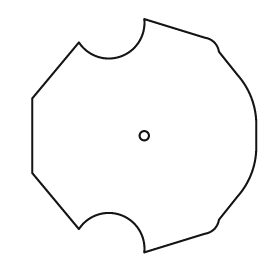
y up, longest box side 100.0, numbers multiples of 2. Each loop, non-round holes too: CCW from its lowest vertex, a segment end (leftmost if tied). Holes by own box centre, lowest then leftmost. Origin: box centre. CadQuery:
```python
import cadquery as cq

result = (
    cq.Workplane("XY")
    .moveTo(0.0, -50.0)
    .lineTo(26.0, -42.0)
    .threePointArc((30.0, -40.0), (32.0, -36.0))
    .lineTo(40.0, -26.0)
    .threePointArc((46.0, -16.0), (48.0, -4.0))
    .lineTo(48.0, 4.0)
    .threePointArc((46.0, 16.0), (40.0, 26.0))
    .lineTo(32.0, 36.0)
    .threePointArc((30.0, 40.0), (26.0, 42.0))
    .lineTo(0.0, 50.0)
    .threePointArc((-10.0, 34.0), (-28.0, 40.0))
    .lineTo(-48.0, 16.0)
    .lineTo(-48.0, -16.0)
    .lineTo(-28.0, -40.0)
    .threePointArc((-10.0, -34.0), (0.0, -50.0))
    .close()
    .moveTo(0.0, 0.0)
    .circle(2.0)
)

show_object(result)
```